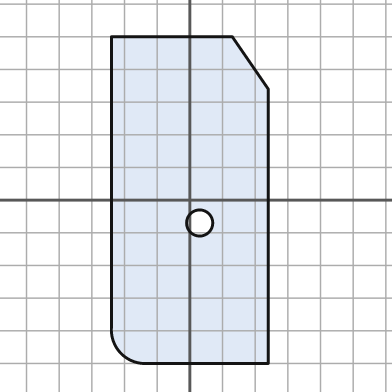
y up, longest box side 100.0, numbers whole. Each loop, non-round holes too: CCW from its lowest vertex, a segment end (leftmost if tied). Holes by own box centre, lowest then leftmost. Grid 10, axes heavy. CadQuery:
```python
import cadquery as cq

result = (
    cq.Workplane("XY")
    .moveTo(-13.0, -50.0)
    .lineTo(24.0, -50.0)
    .lineTo(24.0, 34.0)
    .lineTo(13.0, 50.0)
    .lineTo(-24.0, 50.0)
    .lineTo(-24.0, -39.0)
    .threePointArc((-21.0, -47.0), (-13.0, -50.0))
    .close()
    .moveTo(3.0, -7.0)
    .circle(4.0)
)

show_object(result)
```